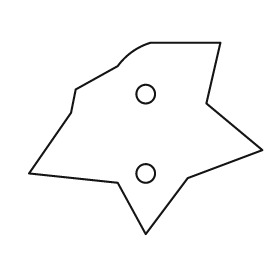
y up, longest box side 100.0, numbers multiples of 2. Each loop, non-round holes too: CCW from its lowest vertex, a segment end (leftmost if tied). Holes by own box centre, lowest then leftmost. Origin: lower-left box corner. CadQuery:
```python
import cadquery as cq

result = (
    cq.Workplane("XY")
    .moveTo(50.0, 0.0)
    .lineTo(68.0, 24.0)
    .lineTo(100.0, 36.0)
    .lineTo(76.0, 56.0)
    .lineTo(82.0, 82.0)
    .lineTo(52.0, 82.0)
    .threePointArc((44.0, 78.0), (38.0, 72.0))
    .lineTo(20.0, 62.0)
    .lineTo(18.0, 52.0)
    .lineTo(0.0, 26.0)
    .lineTo(38.0, 22.0)
    .close()
    .moveTo(50.0, 26.0)
    .circle(4.0)
    .moveTo(50.0, 60.0)
    .circle(4.0)
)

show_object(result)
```